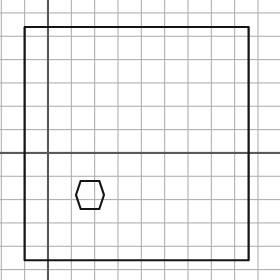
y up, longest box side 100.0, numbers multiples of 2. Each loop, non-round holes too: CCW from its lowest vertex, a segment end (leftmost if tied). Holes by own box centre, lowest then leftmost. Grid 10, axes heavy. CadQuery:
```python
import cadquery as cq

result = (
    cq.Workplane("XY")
    .moveTo(-10.0, -46.0)
    .lineTo(86.0, -46.0)
    .lineTo(86.0, 54.0)
    .lineTo(-10.0, 54.0)
    .close()
    .moveTo(14.0, -24.0)
    .lineTo(22.0, -24.0)
    .lineTo(24.0, -18.0)
    .lineTo(22.0, -12.0)
    .lineTo(14.0, -12.0)
    .lineTo(12.0, -18.0)
    .close()
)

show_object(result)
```